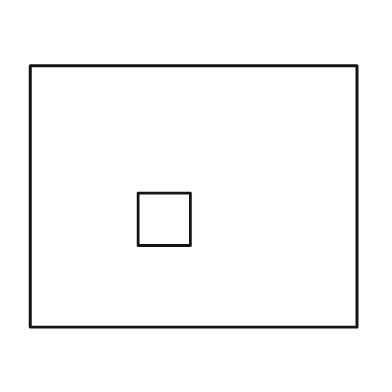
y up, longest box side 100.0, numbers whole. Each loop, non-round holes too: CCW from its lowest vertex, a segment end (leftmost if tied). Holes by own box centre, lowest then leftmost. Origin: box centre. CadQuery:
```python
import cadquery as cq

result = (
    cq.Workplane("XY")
    .moveTo(-50.0, -40.0)
    .lineTo(50.0, -40.0)
    .lineTo(50.0, 40.0)
    .lineTo(-50.0, 40.0)
    .close()
    .moveTo(-17.0, -15.0)
    .lineTo(-1.0, -15.0)
    .lineTo(-1.0, 1.0)
    .lineTo(-17.0, 1.0)
    .close()
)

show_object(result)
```